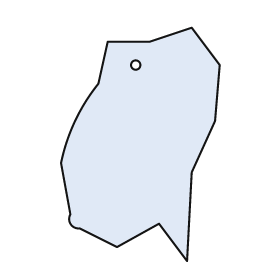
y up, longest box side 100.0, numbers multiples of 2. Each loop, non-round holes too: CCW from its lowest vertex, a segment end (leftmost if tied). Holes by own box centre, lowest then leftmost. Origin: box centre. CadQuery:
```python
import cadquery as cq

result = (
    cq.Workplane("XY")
    .moveTo(20.0, -50.0)
    .lineTo(22.0, -12.0)
    .lineTo(32.0, 10.0)
    .lineTo(34.0, 34.0)
    .lineTo(22.0, 50.0)
    .lineTo(4.0, 44.0)
    .lineTo(-14.0, 44.0)
    .lineTo(-18.0, 26.0)
    .threePointArc((-28.0, 10.0), (-34.0, -8.0))
    .lineTo(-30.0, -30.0)
    .threePointArc((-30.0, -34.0), (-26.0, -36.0))
    .lineTo(-10.0, -44.0)
    .lineTo(8.0, -34.0)
    .close()
    .moveTo(-2.0, 34.0)
    .circle(2.0)
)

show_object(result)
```